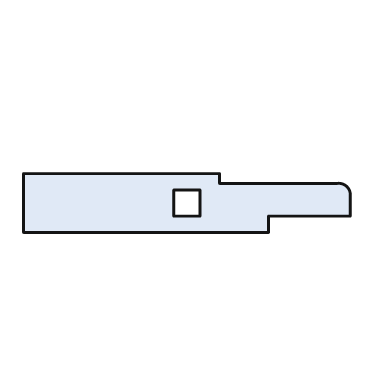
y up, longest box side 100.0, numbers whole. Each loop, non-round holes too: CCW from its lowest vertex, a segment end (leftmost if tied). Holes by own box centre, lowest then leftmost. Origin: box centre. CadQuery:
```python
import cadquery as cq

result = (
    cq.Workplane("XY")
    .moveTo(-50.0, -9.0)
    .lineTo(25.0, -9.0)
    .lineTo(25.0, -4.0)
    .lineTo(50.0, -4.0)
    .lineTo(50.0, 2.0)
    .threePointArc((49.0, 5.0), (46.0, 6.0))
    .lineTo(10.0, 6.0)
    .lineTo(10.0, 9.0)
    .lineTo(-50.0, 9.0)
    .close()
    .moveTo(-4.0, -4.0)
    .lineTo(4.0, -4.0)
    .lineTo(4.0, 4.0)
    .lineTo(-4.0, 4.0)
    .close()
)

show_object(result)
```